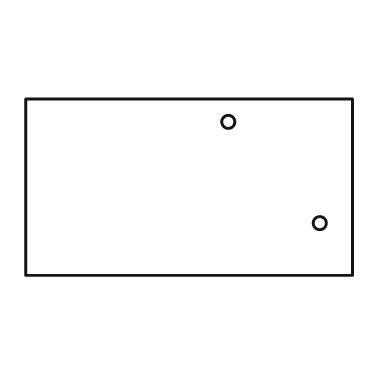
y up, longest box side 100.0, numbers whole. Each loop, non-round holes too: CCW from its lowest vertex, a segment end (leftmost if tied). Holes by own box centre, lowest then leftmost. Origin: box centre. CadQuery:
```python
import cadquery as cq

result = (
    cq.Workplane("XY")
    .moveTo(-50.0, -27.0)
    .lineTo(50.0, -27.0)
    .lineTo(50.0, 27.0)
    .lineTo(-50.0, 27.0)
    .close()
    .moveTo(40.0, -11.0)
    .circle(2.0)
    .moveTo(12.0, 20.0)
    .circle(2.0)
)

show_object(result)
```